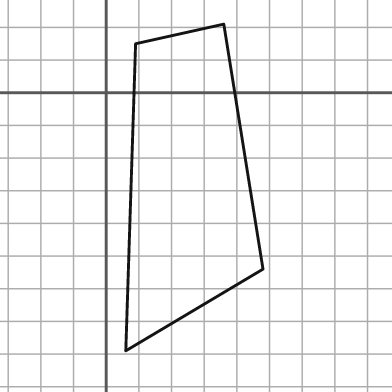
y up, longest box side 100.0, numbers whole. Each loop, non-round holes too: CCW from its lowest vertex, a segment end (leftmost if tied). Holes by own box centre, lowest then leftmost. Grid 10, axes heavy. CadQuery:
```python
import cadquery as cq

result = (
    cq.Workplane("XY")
    .moveTo(6.0, -79.0)
    .lineTo(48.0, -54.0)
    .lineTo(36.0, 21.0)
    .lineTo(9.0, 15.0)
    .close()
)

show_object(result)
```